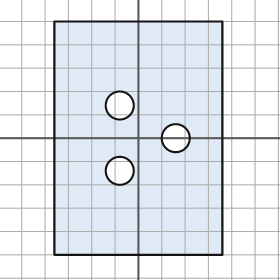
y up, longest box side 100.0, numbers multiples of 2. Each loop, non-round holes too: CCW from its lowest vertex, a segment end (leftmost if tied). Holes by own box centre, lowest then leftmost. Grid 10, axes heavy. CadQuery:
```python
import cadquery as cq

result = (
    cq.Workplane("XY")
    .moveTo(-36.0, -50.0)
    .lineTo(36.0, -50.0)
    .lineTo(36.0, 50.0)
    .lineTo(-36.0, 50.0)
    .close()
    .moveTo(-8.0, -14.0)
    .circle(6.0)
    .moveTo(16.0, 0.0)
    .circle(6.0)
    .moveTo(-8.0, 14.0)
    .circle(6.0)
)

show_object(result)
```